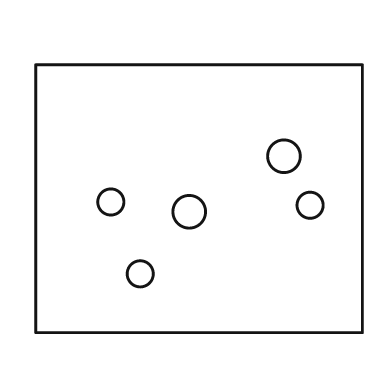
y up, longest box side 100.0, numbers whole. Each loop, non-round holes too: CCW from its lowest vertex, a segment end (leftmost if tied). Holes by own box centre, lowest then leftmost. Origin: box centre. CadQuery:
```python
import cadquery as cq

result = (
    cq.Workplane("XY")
    .moveTo(-50.0, -41.0)
    .lineTo(50.0, -41.0)
    .lineTo(50.0, 41.0)
    .lineTo(-50.0, 41.0)
    .close()
    .moveTo(-18.0, -23.0)
    .circle(4.0)
    .moveTo(-3.0, -4.0)
    .circle(5.0)
    .moveTo(34.0, -2.0)
    .circle(4.0)
    .moveTo(-27.0, -1.0)
    .circle(4.0)
    .moveTo(26.0, 13.0)
    .circle(5.0)
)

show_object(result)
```